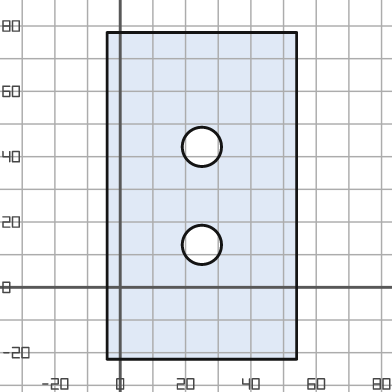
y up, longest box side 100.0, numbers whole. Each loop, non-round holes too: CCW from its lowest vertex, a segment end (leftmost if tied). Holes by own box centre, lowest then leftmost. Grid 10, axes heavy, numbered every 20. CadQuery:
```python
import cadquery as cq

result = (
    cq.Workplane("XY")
    .moveTo(-4.0, -22.0)
    .lineTo(54.0, -22.0)
    .lineTo(54.0, 78.0)
    .lineTo(-4.0, 78.0)
    .close()
    .moveTo(25.0, 13.0)
    .circle(6.0)
    .moveTo(25.0, 43.0)
    .circle(6.0)
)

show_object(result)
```